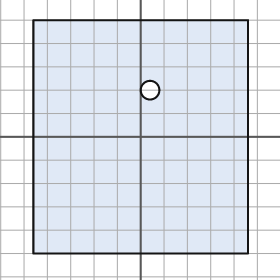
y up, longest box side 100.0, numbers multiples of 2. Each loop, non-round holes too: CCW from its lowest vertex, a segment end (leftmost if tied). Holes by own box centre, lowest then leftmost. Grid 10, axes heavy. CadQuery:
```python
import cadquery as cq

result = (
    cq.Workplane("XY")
    .moveTo(-46.0, -50.0)
    .lineTo(46.0, -50.0)
    .lineTo(46.0, 50.0)
    .lineTo(-46.0, 50.0)
    .close()
    .moveTo(4.0, 20.0)
    .circle(4.0)
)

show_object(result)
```